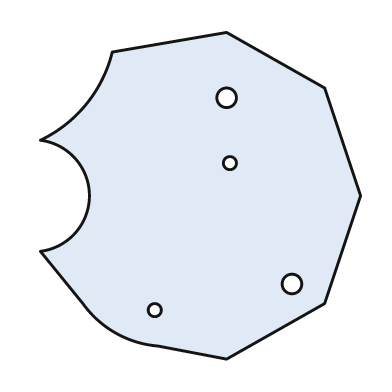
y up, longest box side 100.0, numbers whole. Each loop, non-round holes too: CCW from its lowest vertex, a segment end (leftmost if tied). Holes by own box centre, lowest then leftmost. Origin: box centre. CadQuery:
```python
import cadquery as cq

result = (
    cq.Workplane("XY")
    .moveTo(8.0, -50.0)
    .lineTo(38.0, -33.0)
    .lineTo(49.0, 0.0)
    .lineTo(38.0, 33.0)
    .lineTo(8.0, 50.0)
    .lineTo(-27.0, 44.0)
    .threePointArc((-35.0, 28.0), (-49.0, 17.0))
    .threePointArc((-34.0, 0.0), (-49.0, -17.0))
    .lineTo(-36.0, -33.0)
    .threePointArc((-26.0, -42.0), (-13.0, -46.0))
    .close()
    .moveTo(-14.0, -35.0)
    .circle(2.0)
    .moveTo(28.0, -27.0)
    .circle(3.0)
    .moveTo(9.0, 10.0)
    .circle(2.0)
    .moveTo(8.0, 30.0)
    .circle(3.0)
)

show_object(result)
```